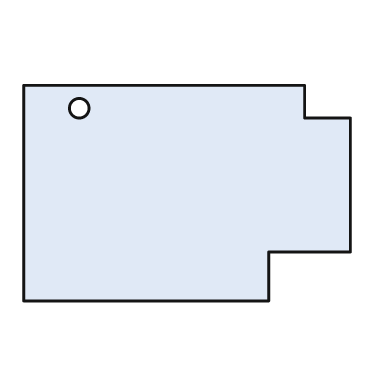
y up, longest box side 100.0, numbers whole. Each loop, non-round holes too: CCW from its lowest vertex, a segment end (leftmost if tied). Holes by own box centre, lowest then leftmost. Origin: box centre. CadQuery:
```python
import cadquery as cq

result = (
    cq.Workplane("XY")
    .moveTo(-50.0, -33.0)
    .lineTo(25.0, -33.0)
    .lineTo(25.0, -18.0)
    .lineTo(50.0, -18.0)
    .lineTo(50.0, 23.0)
    .lineTo(36.0, 23.0)
    .lineTo(36.0, 33.0)
    .lineTo(-50.0, 33.0)
    .close()
    .moveTo(-33.0, 26.0)
    .circle(3.0)
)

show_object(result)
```